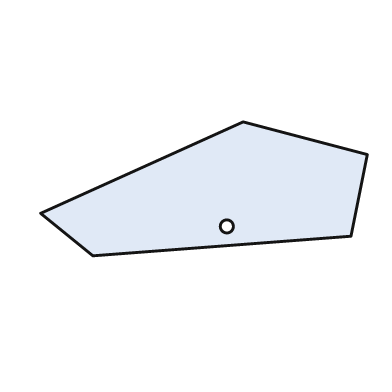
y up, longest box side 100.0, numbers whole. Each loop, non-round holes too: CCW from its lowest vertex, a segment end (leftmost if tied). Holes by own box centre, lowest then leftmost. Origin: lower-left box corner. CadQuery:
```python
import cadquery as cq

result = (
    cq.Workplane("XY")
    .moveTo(16.0, 0.0)
    .lineTo(95.0, 6.0)
    .lineTo(100.0, 31.0)
    .lineTo(62.0, 41.0)
    .lineTo(0.0, 13.0)
    .close()
    .moveTo(57.0, 9.0)
    .circle(2.0)
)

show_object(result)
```